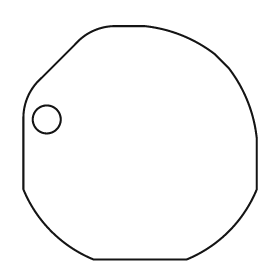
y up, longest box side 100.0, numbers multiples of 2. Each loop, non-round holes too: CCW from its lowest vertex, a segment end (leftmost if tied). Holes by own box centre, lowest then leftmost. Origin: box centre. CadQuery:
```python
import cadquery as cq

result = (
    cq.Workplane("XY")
    .moveTo(-20.0, -50.0)
    .lineTo(20.0, -50.0)
    .threePointArc((38.0, -38.0), (50.0, -20.0))
    .lineTo(50.0, 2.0)
    .threePointArc((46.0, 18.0), (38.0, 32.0))
    .lineTo(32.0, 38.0)
    .threePointArc((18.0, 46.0), (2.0, 50.0))
    .lineTo(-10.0, 50.0)
    .threePointArc((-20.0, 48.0), (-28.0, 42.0))
    .lineTo(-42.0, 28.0)
    .threePointArc((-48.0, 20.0), (-50.0, 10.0))
    .lineTo(-50.0, -20.0)
    .threePointArc((-38.0, -38.0), (-20.0, -50.0))
    .close()
    .moveTo(-40.0, 10.0)
    .circle(6.0)
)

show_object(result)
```